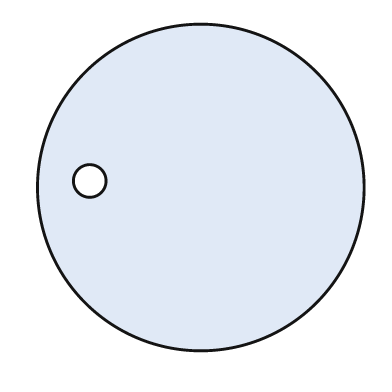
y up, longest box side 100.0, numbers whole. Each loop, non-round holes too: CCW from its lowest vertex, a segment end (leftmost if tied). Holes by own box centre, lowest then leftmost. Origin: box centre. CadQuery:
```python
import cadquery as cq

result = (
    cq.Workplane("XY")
    .moveTo(0.0, 0.0)
    .circle(50.0)
    .moveTo(-34.0, 2.0)
    .circle(5.0)
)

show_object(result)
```